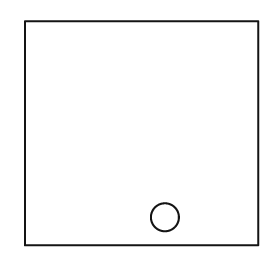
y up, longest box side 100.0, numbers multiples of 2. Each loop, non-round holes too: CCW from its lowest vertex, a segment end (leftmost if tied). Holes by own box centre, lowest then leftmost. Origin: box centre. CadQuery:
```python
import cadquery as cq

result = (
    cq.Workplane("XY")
    .moveTo(-50.0, -48.0)
    .lineTo(50.0, -48.0)
    .lineTo(50.0, 48.0)
    .lineTo(-50.0, 48.0)
    .close()
    .moveTo(10.0, -36.0)
    .circle(6.0)
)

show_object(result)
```